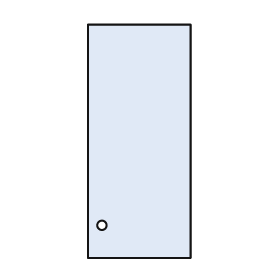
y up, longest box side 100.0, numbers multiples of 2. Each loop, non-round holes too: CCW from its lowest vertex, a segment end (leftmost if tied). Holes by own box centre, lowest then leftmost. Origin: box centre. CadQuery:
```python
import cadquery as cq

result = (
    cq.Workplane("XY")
    .moveTo(-22.0, -50.0)
    .lineTo(22.0, -50.0)
    .lineTo(22.0, 50.0)
    .lineTo(-22.0, 50.0)
    .close()
    .moveTo(-16.0, -36.0)
    .circle(2.0)
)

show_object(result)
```